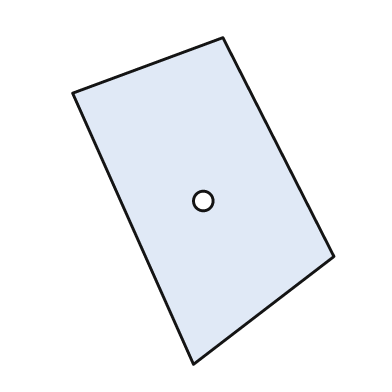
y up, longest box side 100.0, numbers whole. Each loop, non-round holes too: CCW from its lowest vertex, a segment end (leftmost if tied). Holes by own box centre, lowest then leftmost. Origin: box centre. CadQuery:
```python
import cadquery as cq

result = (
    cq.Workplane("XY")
    .moveTo(-3.0, -50.0)
    .lineTo(40.0, -17.0)
    .lineTo(6.0, 50.0)
    .lineTo(-40.0, 33.0)
    .close()
    .moveTo(0.0, 0.0)
    .circle(3.0)
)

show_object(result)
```